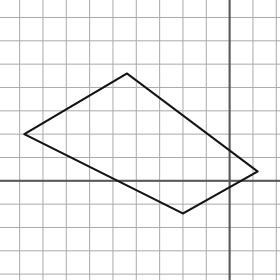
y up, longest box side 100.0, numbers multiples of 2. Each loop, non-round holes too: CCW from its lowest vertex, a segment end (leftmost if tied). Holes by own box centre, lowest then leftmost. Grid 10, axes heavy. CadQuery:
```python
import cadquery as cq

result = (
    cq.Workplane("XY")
    .moveTo(-20.0, -14.0)
    .lineTo(12.0, 4.0)
    .lineTo(-44.0, 46.0)
    .lineTo(-88.0, 20.0)
    .close()
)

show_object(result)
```